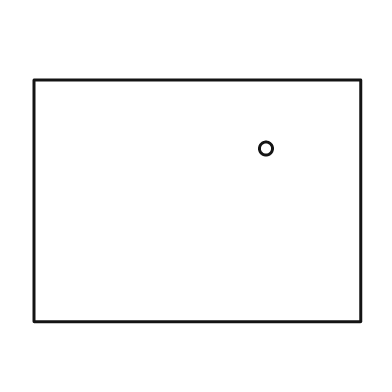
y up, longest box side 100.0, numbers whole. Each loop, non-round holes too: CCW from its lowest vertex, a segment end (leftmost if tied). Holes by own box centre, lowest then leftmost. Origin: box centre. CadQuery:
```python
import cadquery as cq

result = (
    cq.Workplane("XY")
    .moveTo(-50.0, -37.0)
    .lineTo(50.0, -37.0)
    .lineTo(50.0, 37.0)
    .lineTo(-50.0, 37.0)
    .close()
    .moveTo(21.0, 16.0)
    .circle(2.0)
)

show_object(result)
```